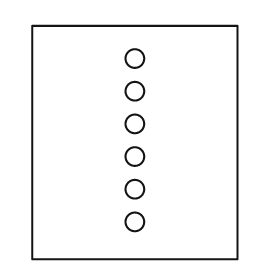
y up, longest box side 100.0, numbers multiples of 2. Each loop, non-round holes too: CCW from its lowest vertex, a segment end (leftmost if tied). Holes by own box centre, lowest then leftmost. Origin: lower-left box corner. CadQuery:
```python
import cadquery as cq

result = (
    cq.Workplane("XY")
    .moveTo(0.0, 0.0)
    .lineTo(88.0, 0.0)
    .lineTo(88.0, 100.0)
    .lineTo(0.0, 100.0)
    .close()
    .moveTo(44.0, 16.0)
    .circle(4.0)
    .moveTo(44.0, 30.0)
    .circle(4.0)
    .moveTo(44.0, 44.0)
    .circle(4.0)
    .moveTo(44.0, 58.0)
    .circle(4.0)
    .moveTo(44.0, 72.0)
    .circle(4.0)
    .moveTo(44.0, 86.0)
    .circle(4.0)
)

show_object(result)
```